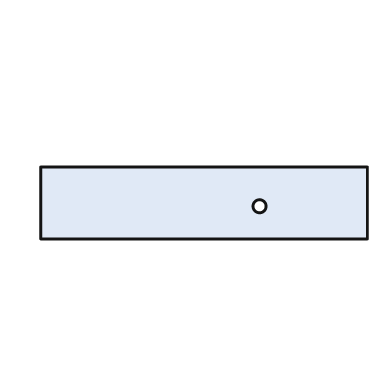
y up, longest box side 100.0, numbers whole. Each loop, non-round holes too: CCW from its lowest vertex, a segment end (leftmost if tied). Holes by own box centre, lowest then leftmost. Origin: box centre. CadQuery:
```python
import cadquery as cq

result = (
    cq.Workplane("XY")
    .moveTo(-50.0, -11.0)
    .lineTo(50.0, -11.0)
    .lineTo(50.0, 11.0)
    .lineTo(-50.0, 11.0)
    .close()
    .moveTo(17.0, -1.0)
    .circle(2.0)
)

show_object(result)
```